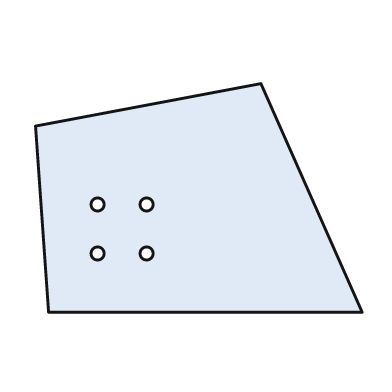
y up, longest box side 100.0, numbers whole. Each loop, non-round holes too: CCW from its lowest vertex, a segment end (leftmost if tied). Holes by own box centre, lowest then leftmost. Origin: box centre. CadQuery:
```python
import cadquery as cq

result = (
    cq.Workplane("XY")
    .moveTo(-46.0, -35.0)
    .lineTo(50.0, -35.0)
    .lineTo(19.0, 35.0)
    .lineTo(-50.0, 22.0)
    .close()
    .moveTo(-31.0, -17.0)
    .circle(2.0)
    .moveTo(-16.0, -17.0)
    .circle(2.0)
    .moveTo(-31.0, -2.0)
    .circle(2.0)
    .moveTo(-16.0, -2.0)
    .circle(2.0)
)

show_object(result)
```